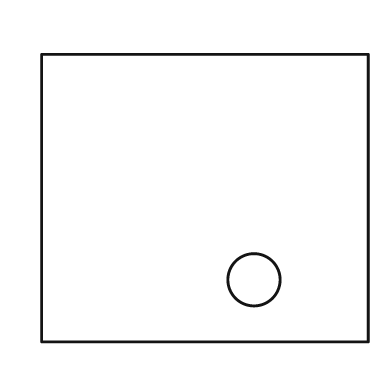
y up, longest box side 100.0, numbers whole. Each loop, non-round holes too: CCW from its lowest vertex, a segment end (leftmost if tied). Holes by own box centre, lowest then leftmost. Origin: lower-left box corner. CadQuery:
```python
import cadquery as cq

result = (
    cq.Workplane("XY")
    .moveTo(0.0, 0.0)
    .lineTo(100.0, 0.0)
    .lineTo(100.0, 88.0)
    .lineTo(0.0, 88.0)
    .close()
    .moveTo(65.0, 19.0)
    .circle(8.0)
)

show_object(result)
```